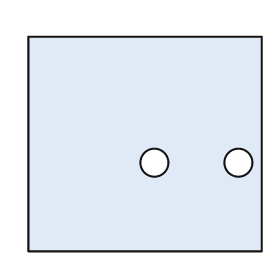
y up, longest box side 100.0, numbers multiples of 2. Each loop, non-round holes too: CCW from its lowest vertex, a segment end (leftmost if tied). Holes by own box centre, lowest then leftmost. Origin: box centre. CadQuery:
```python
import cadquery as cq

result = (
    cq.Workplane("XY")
    .moveTo(-50.0, -46.0)
    .lineTo(50.0, -46.0)
    .lineTo(50.0, 46.0)
    .lineTo(-50.0, 46.0)
    .close()
    .moveTo(4.0, -8.0)
    .circle(6.0)
    .moveTo(40.0, -8.0)
    .circle(6.0)
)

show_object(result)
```